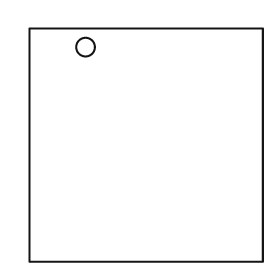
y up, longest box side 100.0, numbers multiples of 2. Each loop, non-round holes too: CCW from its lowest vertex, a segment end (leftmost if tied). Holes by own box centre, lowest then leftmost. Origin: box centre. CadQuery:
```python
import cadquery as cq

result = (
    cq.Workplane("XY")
    .moveTo(-50.0, -50.0)
    .lineTo(50.0, -50.0)
    .lineTo(50.0, 50.0)
    .lineTo(-50.0, 50.0)
    .close()
    .moveTo(-26.0, 42.0)
    .circle(4.0)
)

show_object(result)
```